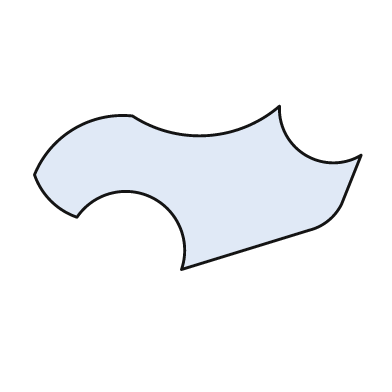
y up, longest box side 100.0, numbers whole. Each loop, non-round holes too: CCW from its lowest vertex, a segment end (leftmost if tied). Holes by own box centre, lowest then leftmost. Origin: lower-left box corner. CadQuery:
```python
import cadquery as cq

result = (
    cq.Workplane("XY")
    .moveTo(45.0, 0.0)
    .lineTo(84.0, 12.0)
    .threePointArc((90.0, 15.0), (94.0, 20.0))
    .lineTo(100.0, 35.0)
    .threePointArc((83.0, 35.0), (75.0, 50.0))
    .threePointArc((53.0, 41.0), (30.0, 47.0))
    .threePointArc((12.0, 43.0), (0.0, 29.0))
    .threePointArc((5.0, 21.0), (13.0, 16.0))
    .threePointArc((36.0, 22.0), (45.0, 0.0))
    .close()
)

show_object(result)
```